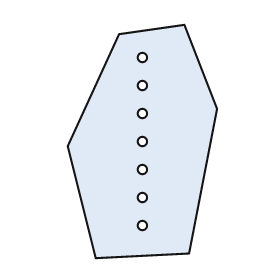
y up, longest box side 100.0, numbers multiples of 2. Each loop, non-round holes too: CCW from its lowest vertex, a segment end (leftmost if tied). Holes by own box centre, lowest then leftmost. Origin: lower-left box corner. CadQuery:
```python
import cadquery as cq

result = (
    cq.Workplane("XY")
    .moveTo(12.0, 0.0)
    .lineTo(52.0, 2.0)
    .lineTo(64.0, 64.0)
    .lineTo(50.0, 100.0)
    .lineTo(22.0, 96.0)
    .lineTo(0.0, 48.0)
    .close()
    .moveTo(32.0, 14.0)
    .circle(2.0)
    .moveTo(32.0, 26.0)
    .circle(2.0)
    .moveTo(32.0, 38.0)
    .circle(2.0)
    .moveTo(32.0, 50.0)
    .circle(2.0)
    .moveTo(32.0, 62.0)
    .circle(2.0)
    .moveTo(32.0, 74.0)
    .circle(2.0)
    .moveTo(32.0, 86.0)
    .circle(2.0)
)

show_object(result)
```